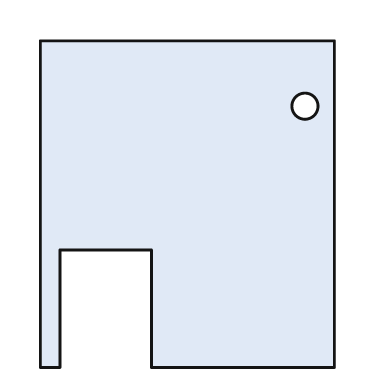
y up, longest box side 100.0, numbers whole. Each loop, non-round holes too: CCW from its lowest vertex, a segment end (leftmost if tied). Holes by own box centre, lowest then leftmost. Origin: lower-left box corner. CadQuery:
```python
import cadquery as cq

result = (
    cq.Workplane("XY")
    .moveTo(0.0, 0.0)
    .lineTo(6.0, 0.0)
    .lineTo(6.0, 36.0)
    .lineTo(34.0, 36.0)
    .lineTo(34.0, 0.0)
    .lineTo(90.0, 0.0)
    .lineTo(90.0, 100.0)
    .lineTo(0.0, 100.0)
    .close()
    .moveTo(81.0, 80.0)
    .circle(4.0)
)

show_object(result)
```